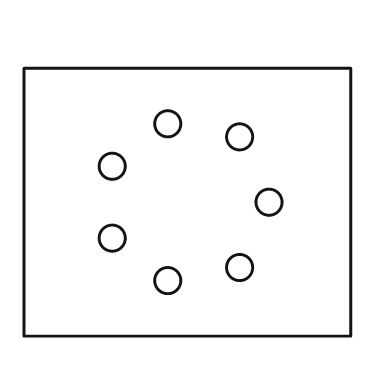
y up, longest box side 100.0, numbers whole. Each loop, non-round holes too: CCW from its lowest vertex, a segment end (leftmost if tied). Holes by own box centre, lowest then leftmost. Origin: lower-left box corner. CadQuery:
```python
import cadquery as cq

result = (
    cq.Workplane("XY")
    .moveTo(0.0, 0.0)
    .lineTo(100.0, 0.0)
    .lineTo(100.0, 82.0)
    .lineTo(0.0, 82.0)
    .close()
    .moveTo(44.0, 17.0)
    .circle(4.0)
    .moveTo(66.0, 21.0)
    .circle(4.0)
    .moveTo(27.0, 30.0)
    .circle(4.0)
    .moveTo(75.0, 41.0)
    .circle(4.0)
    .moveTo(27.0, 52.0)
    .circle(4.0)
    .moveTo(66.0, 61.0)
    .circle(4.0)
    .moveTo(44.0, 65.0)
    .circle(4.0)
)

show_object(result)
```